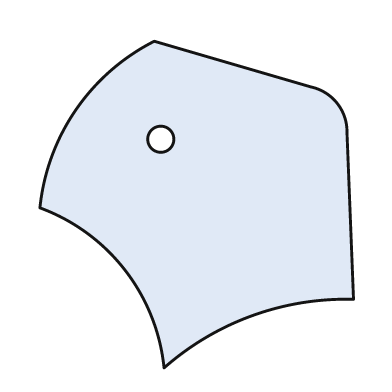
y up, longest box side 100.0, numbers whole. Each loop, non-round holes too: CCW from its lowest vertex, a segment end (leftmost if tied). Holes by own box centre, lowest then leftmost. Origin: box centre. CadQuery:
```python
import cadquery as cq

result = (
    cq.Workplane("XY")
    .moveTo(-10.0, -50.0)
    .threePointArc((17.0, -34.0), (48.0, -29.0))
    .lineTo(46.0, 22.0)
    .threePointArc((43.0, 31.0), (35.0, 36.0))
    .lineTo(-13.0, 50.0)
    .threePointArc((-37.0, 29.0), (-48.0, -1.0))
    .threePointArc((-22.0, -20.0), (-10.0, -50.0))
    .close()
    .moveTo(-11.0, 20.0)
    .circle(4.0)
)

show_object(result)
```